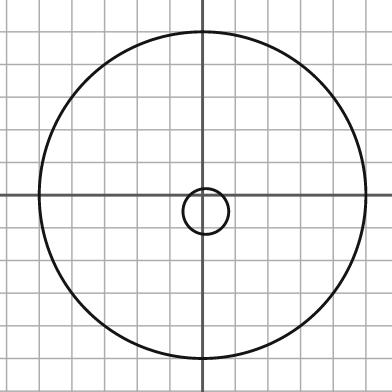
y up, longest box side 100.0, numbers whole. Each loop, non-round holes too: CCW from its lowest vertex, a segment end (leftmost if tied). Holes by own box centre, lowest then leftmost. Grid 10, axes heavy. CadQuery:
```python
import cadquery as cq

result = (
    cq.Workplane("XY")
    .moveTo(0.0, 0.0)
    .circle(50.0)
    .moveTo(1.0, -5.0)
    .circle(7.0)
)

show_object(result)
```